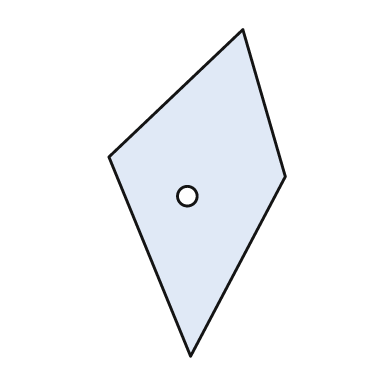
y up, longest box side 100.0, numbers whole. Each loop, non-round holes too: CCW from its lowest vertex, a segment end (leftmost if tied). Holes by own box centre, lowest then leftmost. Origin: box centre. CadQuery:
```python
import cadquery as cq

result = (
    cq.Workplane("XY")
    .moveTo(-2.0, -50.0)
    .lineTo(27.0, 5.0)
    .lineTo(14.0, 50.0)
    .lineTo(-27.0, 11.0)
    .close()
    .moveTo(-3.0, -1.0)
    .circle(3.0)
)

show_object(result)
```